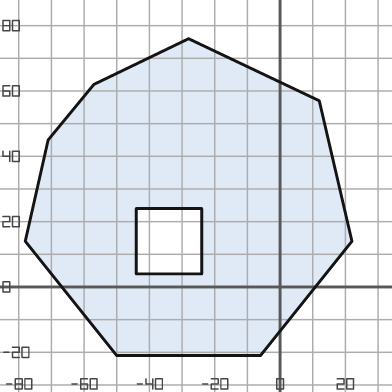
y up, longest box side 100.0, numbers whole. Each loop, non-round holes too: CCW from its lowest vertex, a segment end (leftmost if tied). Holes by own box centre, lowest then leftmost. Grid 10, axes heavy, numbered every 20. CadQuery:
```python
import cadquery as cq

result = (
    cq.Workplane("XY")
    .moveTo(-50.0, -21.0)
    .lineTo(-6.0, -21.0)
    .lineTo(22.0, 14.0)
    .lineTo(12.0, 57.0)
    .lineTo(-28.0, 76.0)
    .lineTo(-57.0, 62.0)
    .lineTo(-71.0, 45.0)
    .lineTo(-78.0, 14.0)
    .close()
    .moveTo(-44.0, 4.0)
    .lineTo(-24.0, 4.0)
    .lineTo(-24.0, 24.0)
    .lineTo(-44.0, 24.0)
    .close()
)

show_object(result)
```